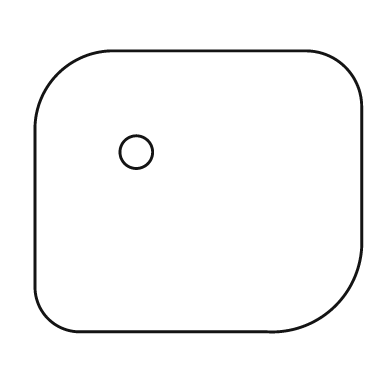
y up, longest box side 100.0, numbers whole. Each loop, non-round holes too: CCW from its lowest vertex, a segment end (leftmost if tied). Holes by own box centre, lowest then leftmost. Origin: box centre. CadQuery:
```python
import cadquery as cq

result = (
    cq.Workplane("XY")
    .moveTo(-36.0, -43.0)
    .lineTo(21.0, -43.0)
    .threePointArc((42.0, -35.0), (50.0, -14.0))
    .lineTo(50.0, 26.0)
    .threePointArc((45.0, 38.0), (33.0, 43.0))
    .lineTo(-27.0, 43.0)
    .threePointArc((-43.0, 36.0), (-50.0, 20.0))
    .lineTo(-50.0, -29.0)
    .threePointArc((-46.0, -39.0), (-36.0, -43.0))
    .close()
    .moveTo(-19.0, 12.0)
    .circle(5.0)
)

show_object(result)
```